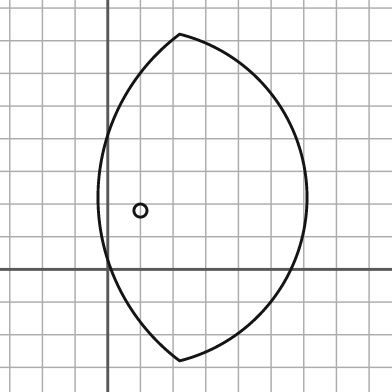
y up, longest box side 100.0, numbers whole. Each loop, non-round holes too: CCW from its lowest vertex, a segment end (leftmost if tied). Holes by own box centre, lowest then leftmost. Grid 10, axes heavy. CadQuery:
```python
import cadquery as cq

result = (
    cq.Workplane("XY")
    .moveTo(22.0, -28.0)
    .threePointArc((61.0, 22.0), (22.0, 72.0))
    .threePointArc((-3.0, 22.0), (22.0, -28.0))
    .close()
    .moveTo(10.0, 18.0)
    .circle(2.0)
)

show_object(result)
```